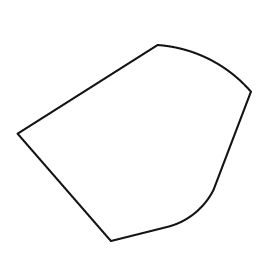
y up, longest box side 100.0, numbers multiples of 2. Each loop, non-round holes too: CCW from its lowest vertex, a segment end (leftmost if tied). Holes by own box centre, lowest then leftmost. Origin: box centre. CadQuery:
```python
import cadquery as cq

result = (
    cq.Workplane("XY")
    .moveTo(-10.0, -42.0)
    .lineTo(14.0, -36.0)
    .threePointArc((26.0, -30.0), (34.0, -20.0))
    .lineTo(50.0, 22.0)
    .threePointArc((32.0, 36.0), (10.0, 42.0))
    .lineTo(-50.0, 4.0)
    .close()
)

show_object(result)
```